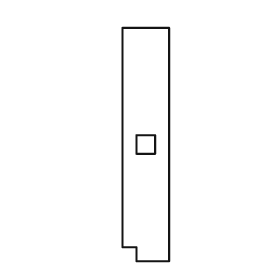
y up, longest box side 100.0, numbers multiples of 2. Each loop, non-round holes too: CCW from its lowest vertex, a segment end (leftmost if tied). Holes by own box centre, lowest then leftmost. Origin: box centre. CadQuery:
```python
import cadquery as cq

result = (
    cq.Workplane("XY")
    .moveTo(-4.0, -50.0)
    .lineTo(10.0, -50.0)
    .lineTo(10.0, 50.0)
    .lineTo(-10.0, 50.0)
    .lineTo(-10.0, -44.0)
    .lineTo(-4.0, -44.0)
    .close()
    .moveTo(-4.0, -4.0)
    .lineTo(4.0, -4.0)
    .lineTo(4.0, 4.0)
    .lineTo(-4.0, 4.0)
    .close()
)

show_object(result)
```